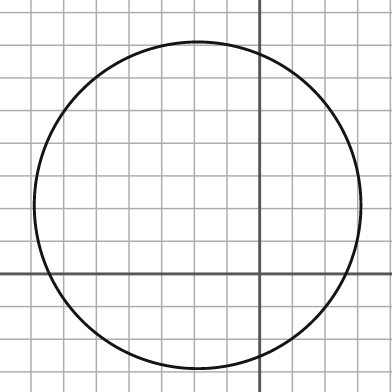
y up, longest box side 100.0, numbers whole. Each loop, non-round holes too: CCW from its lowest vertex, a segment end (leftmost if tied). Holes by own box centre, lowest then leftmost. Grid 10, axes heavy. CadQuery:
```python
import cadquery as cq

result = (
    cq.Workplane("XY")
    .moveTo(-19.0, 21.0)
    .circle(50.0)
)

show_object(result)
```